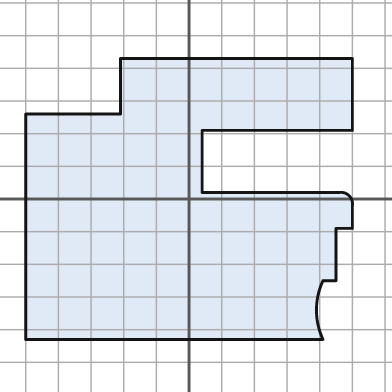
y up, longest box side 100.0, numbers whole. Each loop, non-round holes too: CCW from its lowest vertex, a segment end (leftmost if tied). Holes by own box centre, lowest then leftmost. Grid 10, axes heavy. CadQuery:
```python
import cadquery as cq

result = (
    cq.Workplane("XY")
    .moveTo(-50.0, -43.0)
    .lineTo(41.0, -43.0)
    .threePointArc((39.0, -34.0), (41.0, -25.0))
    .lineTo(45.0, -25.0)
    .lineTo(45.0, -9.0)
    .lineTo(50.0, -9.0)
    .lineTo(50.0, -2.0)
    .threePointArc((49.0, 1.0), (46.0, 2.0))
    .lineTo(4.0, 2.0)
    .lineTo(4.0, 21.0)
    .lineTo(50.0, 21.0)
    .lineTo(50.0, 43.0)
    .lineTo(-21.0, 43.0)
    .lineTo(-21.0, 26.0)
    .lineTo(-50.0, 26.0)
    .close()
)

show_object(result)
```